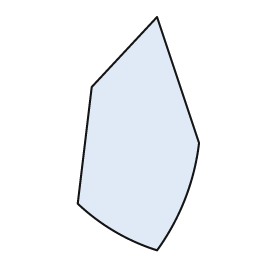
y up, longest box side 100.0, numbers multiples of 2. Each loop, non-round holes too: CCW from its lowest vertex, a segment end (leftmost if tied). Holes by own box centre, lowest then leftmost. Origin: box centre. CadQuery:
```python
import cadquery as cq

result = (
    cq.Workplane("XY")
    .moveTo(8.0, -50.0)
    .threePointArc((20.0, -28.0), (26.0, -4.0))
    .lineTo(8.0, 50.0)
    .lineTo(-20.0, 20.0)
    .lineTo(-26.0, -30.0)
    .threePointArc((-10.0, -42.0), (8.0, -50.0))
    .close()
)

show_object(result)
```